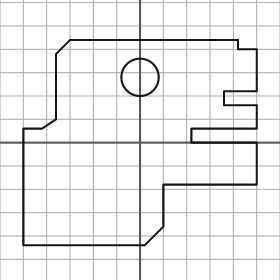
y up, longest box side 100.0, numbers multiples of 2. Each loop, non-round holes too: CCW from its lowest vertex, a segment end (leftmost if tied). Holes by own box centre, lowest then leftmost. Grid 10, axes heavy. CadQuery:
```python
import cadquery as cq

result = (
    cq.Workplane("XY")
    .moveTo(-50.0, -44.0)
    .lineTo(2.0, -44.0)
    .lineTo(10.0, -36.0)
    .lineTo(10.0, -18.0)
    .lineTo(50.0, -18.0)
    .lineTo(50.0, 0.0)
    .lineTo(22.0, 0.0)
    .lineTo(22.0, 6.0)
    .lineTo(50.0, 6.0)
    .lineTo(50.0, 16.0)
    .lineTo(36.0, 16.0)
    .lineTo(36.0, 22.0)
    .lineTo(50.0, 22.0)
    .lineTo(50.0, 40.0)
    .lineTo(42.0, 40.0)
    .lineTo(42.0, 44.0)
    .lineTo(-30.0, 44.0)
    .lineTo(-36.0, 38.0)
    .lineTo(-36.0, 10.0)
    .lineTo(-42.0, 6.0)
    .lineTo(-50.0, 6.0)
    .close()
    .moveTo(0.0, 28.0)
    .circle(8.0)
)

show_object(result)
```